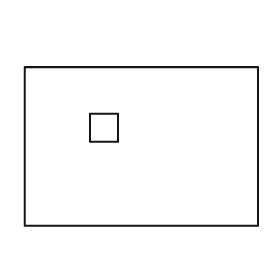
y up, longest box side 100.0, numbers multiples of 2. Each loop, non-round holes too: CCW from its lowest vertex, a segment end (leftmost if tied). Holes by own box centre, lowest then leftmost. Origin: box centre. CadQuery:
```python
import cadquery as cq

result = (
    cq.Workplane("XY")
    .moveTo(-50.0, -34.0)
    .lineTo(50.0, -34.0)
    .lineTo(50.0, 34.0)
    .lineTo(-50.0, 34.0)
    .close()
    .moveTo(-22.0, 2.0)
    .lineTo(-10.0, 2.0)
    .lineTo(-10.0, 14.0)
    .lineTo(-22.0, 14.0)
    .close()
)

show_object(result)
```